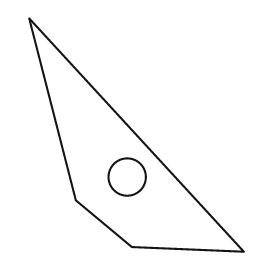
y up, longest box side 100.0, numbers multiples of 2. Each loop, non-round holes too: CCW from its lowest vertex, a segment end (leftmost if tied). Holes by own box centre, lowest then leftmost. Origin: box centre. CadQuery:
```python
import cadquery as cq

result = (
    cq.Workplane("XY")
    .moveTo(46.0, -50.0)
    .lineTo(-46.0, 50.0)
    .lineTo(-26.0, -28.0)
    .lineTo(-2.0, -48.0)
    .close()
    .moveTo(-4.0, -18.0)
    .circle(8.0)
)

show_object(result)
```